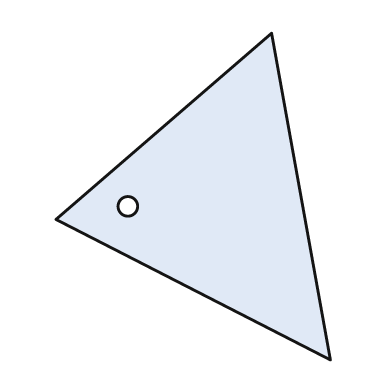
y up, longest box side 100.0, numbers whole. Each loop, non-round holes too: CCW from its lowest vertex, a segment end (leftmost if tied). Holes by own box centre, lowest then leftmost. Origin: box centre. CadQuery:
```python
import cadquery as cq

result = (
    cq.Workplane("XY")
    .moveTo(42.0, -50.0)
    .lineTo(24.0, 50.0)
    .lineTo(-42.0, -7.0)
    .close()
    .moveTo(-20.0, -3.0)
    .circle(3.0)
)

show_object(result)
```